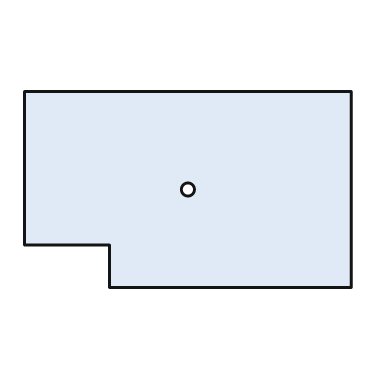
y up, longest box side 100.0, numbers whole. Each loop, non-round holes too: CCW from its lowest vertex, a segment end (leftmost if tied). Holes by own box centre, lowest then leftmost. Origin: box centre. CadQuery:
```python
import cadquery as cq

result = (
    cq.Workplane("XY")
    .moveTo(-24.0, -30.0)
    .lineTo(50.0, -30.0)
    .lineTo(50.0, 30.0)
    .lineTo(-50.0, 30.0)
    .lineTo(-50.0, -17.0)
    .lineTo(-24.0, -17.0)
    .close()
    .moveTo(0.0, 0.0)
    .circle(2.0)
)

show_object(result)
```